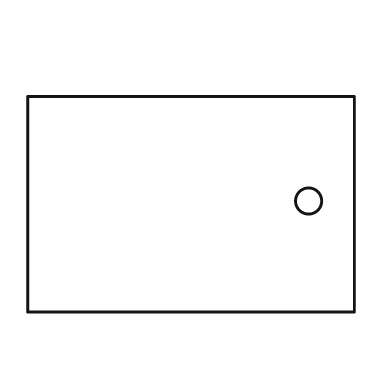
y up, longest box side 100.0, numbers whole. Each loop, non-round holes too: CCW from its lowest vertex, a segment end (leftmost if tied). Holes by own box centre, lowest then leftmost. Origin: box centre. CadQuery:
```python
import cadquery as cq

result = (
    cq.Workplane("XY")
    .moveTo(-50.0, -33.0)
    .lineTo(50.0, -33.0)
    .lineTo(50.0, 33.0)
    .lineTo(-50.0, 33.0)
    .close()
    .moveTo(36.0, 1.0)
    .circle(4.0)
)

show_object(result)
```